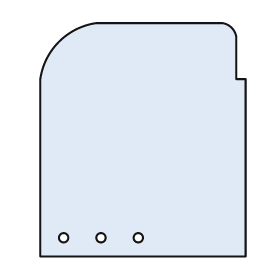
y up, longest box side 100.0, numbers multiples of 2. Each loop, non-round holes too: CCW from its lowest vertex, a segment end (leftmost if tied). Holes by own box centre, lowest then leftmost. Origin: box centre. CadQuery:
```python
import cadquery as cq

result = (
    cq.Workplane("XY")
    .moveTo(-44.0, -50.0)
    .lineTo(44.0, -50.0)
    .lineTo(44.0, 26.0)
    .lineTo(40.0, 26.0)
    .lineTo(40.0, 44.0)
    .threePointArc((38.0, 48.0), (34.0, 50.0))
    .lineTo(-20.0, 50.0)
    .threePointArc((-36.0, 42.0), (-44.0, 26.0))
    .close()
    .moveTo(-34.0, -42.0)
    .circle(2.0)
    .moveTo(-18.0, -42.0)
    .circle(2.0)
    .moveTo(-2.0, -42.0)
    .circle(2.0)
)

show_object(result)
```